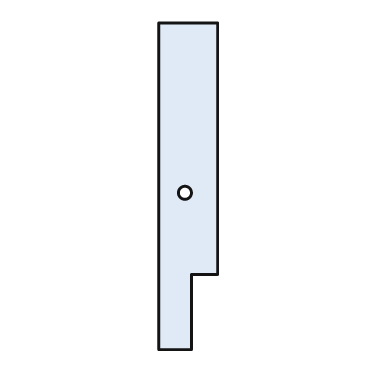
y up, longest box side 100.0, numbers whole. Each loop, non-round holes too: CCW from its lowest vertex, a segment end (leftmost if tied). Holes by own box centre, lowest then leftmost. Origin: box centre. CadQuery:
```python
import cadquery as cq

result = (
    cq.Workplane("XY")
    .moveTo(-9.0, -50.0)
    .lineTo(1.0, -50.0)
    .lineTo(1.0, -27.0)
    .lineTo(9.0, -27.0)
    .lineTo(9.0, 50.0)
    .lineTo(-9.0, 50.0)
    .close()
    .moveTo(-1.0, -2.0)
    .circle(2.0)
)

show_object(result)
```